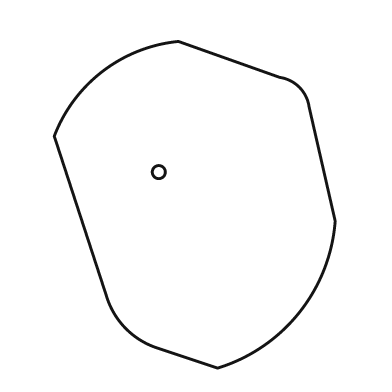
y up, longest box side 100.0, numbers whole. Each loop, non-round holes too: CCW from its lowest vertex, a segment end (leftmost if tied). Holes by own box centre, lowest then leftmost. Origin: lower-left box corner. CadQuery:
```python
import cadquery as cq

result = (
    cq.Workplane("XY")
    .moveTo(50.0, 0.0)
    .threePointArc((75.0, 17.0), (86.0, 45.0))
    .lineTo(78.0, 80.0)
    .threePointArc((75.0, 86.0), (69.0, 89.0))
    .lineTo(38.0, 100.0)
    .threePointArc((15.0, 91.0), (0.0, 71.0))
    .lineTo(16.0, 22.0)
    .threePointArc((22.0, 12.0), (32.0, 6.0))
    .close()
    .moveTo(32.0, 60.0)
    .circle(2.0)
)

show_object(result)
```